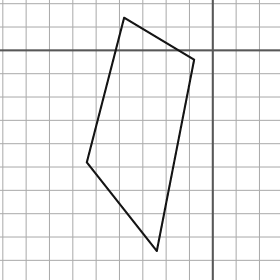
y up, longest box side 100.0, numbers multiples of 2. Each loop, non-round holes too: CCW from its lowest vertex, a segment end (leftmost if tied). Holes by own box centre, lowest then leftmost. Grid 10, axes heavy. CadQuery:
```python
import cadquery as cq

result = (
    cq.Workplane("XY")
    .moveTo(-24.0, -86.0)
    .lineTo(-8.0, -4.0)
    .lineTo(-38.0, 14.0)
    .lineTo(-54.0, -48.0)
    .close()
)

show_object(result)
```